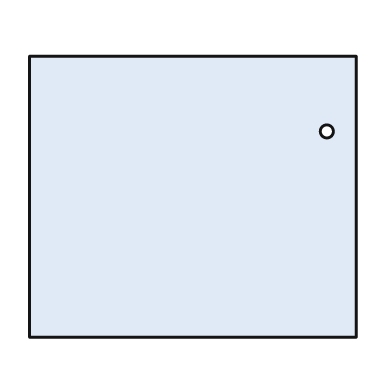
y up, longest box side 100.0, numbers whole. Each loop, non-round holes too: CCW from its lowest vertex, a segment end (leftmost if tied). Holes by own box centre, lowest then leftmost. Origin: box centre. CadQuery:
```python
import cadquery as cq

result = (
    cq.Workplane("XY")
    .moveTo(-50.0, -43.0)
    .lineTo(50.0, -43.0)
    .lineTo(50.0, 43.0)
    .lineTo(-50.0, 43.0)
    .close()
    .moveTo(41.0, 20.0)
    .circle(2.0)
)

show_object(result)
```